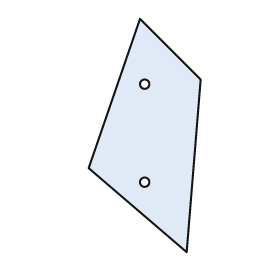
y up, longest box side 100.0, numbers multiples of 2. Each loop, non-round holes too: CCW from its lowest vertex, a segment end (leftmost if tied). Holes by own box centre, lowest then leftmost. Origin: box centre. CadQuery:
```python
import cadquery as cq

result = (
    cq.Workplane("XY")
    .moveTo(18.0, -50.0)
    .lineTo(24.0, 24.0)
    .lineTo(-2.0, 50.0)
    .lineTo(-24.0, -14.0)
    .close()
    .moveTo(0.0, -20.0)
    .circle(2.0)
    .moveTo(0.0, 22.0)
    .circle(2.0)
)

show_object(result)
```